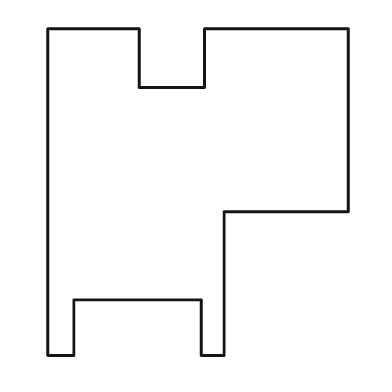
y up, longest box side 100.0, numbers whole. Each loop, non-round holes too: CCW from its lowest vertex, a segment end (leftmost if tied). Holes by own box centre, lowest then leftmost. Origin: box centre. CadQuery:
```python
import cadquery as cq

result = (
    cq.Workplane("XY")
    .moveTo(-46.0, -50.0)
    .lineTo(-38.0, -50.0)
    .lineTo(-38.0, -33.0)
    .lineTo(1.0, -33.0)
    .lineTo(1.0, -50.0)
    .lineTo(8.0, -50.0)
    .lineTo(8.0, -6.0)
    .lineTo(46.0, -6.0)
    .lineTo(46.0, 50.0)
    .lineTo(2.0, 50.0)
    .lineTo(2.0, 32.0)
    .lineTo(-18.0, 32.0)
    .lineTo(-18.0, 50.0)
    .lineTo(-46.0, 50.0)
    .close()
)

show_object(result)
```